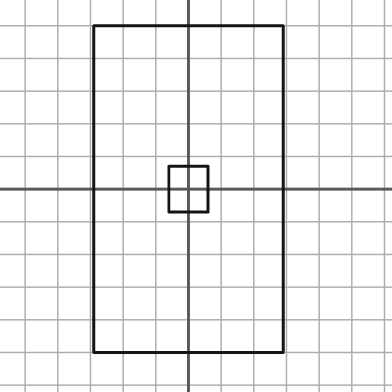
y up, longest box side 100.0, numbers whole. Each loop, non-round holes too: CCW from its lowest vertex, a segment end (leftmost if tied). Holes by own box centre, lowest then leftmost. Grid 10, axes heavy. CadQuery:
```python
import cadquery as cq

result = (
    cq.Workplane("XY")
    .moveTo(-29.0, -50.0)
    .lineTo(29.0, -50.0)
    .lineTo(29.0, 50.0)
    .lineTo(-29.0, 50.0)
    .close()
    .moveTo(-6.0, -7.0)
    .lineTo(6.0, -7.0)
    .lineTo(6.0, 7.0)
    .lineTo(-6.0, 7.0)
    .close()
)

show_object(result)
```